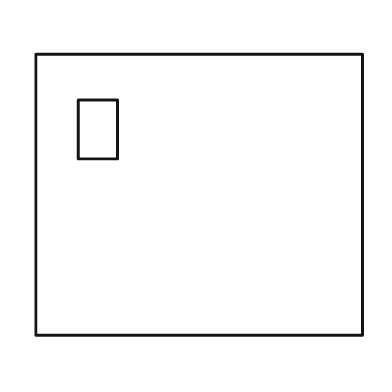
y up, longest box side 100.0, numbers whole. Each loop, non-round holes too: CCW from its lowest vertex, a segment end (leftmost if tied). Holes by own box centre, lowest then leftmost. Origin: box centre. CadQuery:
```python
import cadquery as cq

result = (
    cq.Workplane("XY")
    .moveTo(-50.0, -43.0)
    .lineTo(50.0, -43.0)
    .lineTo(50.0, 43.0)
    .lineTo(-50.0, 43.0)
    .close()
    .moveTo(-37.0, 11.0)
    .lineTo(-25.0, 11.0)
    .lineTo(-25.0, 29.0)
    .lineTo(-37.0, 29.0)
    .close()
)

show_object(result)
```